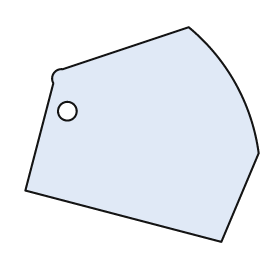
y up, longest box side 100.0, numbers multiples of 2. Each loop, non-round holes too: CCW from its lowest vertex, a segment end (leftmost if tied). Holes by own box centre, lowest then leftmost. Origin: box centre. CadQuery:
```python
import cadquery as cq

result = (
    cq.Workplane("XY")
    .moveTo(34.0, -46.0)
    .lineTo(50.0, -8.0)
    .threePointArc((40.0, 22.0), (20.0, 46.0))
    .lineTo(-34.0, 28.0)
    .threePointArc((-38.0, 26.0), (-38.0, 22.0))
    .lineTo(-50.0, -24.0)
    .close()
    .moveTo(-32.0, 10.0)
    .circle(4.0)
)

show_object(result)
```